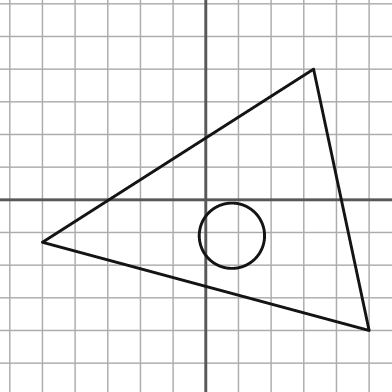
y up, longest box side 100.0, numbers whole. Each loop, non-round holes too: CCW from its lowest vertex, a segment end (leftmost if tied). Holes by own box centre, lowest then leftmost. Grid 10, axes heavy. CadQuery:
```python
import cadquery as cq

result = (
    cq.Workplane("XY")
    .moveTo(50.0, -40.0)
    .lineTo(33.0, 40.0)
    .lineTo(-50.0, -13.0)
    .close()
    .moveTo(8.0, -11.0)
    .circle(10.0)
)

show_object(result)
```